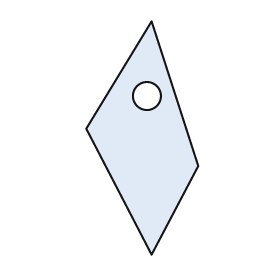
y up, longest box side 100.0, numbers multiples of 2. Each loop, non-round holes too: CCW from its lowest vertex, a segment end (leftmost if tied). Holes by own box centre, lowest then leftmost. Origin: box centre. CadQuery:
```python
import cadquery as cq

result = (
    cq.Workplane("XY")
    .moveTo(4.0, -50.0)
    .lineTo(24.0, -12.0)
    .lineTo(4.0, 50.0)
    .lineTo(-24.0, 4.0)
    .close()
    .moveTo(2.0, 18.0)
    .circle(6.0)
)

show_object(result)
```